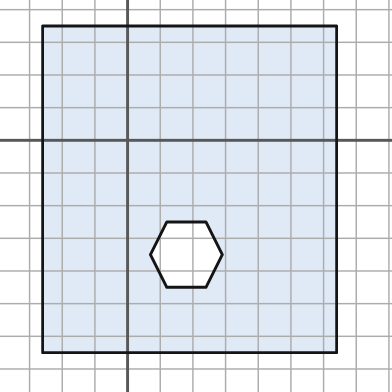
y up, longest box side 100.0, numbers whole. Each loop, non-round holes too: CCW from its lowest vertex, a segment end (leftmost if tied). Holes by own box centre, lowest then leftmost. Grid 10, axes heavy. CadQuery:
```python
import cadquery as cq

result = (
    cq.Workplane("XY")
    .moveTo(-26.0, -65.0)
    .lineTo(64.0, -65.0)
    .lineTo(64.0, 35.0)
    .lineTo(-26.0, 35.0)
    .close()
    .moveTo(12.0, -45.0)
    .lineTo(24.0, -45.0)
    .lineTo(29.0, -35.0)
    .lineTo(24.0, -25.0)
    .lineTo(12.0, -25.0)
    .lineTo(7.0, -35.0)
    .close()
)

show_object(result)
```